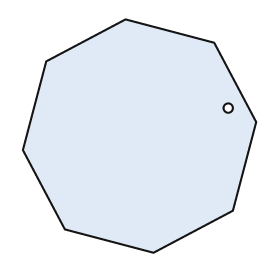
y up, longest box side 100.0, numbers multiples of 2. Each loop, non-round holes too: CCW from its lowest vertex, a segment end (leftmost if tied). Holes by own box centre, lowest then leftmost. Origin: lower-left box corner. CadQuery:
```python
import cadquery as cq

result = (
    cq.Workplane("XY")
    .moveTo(56.0, 0.0)
    .lineTo(90.0, 18.0)
    .lineTo(100.0, 56.0)
    .lineTo(82.0, 90.0)
    .lineTo(44.0, 100.0)
    .lineTo(10.0, 82.0)
    .lineTo(0.0, 44.0)
    .lineTo(18.0, 10.0)
    .close()
    .moveTo(88.0, 62.0)
    .circle(2.0)
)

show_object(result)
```